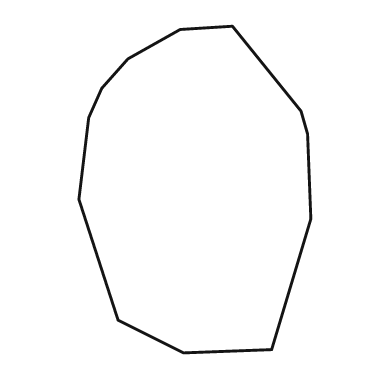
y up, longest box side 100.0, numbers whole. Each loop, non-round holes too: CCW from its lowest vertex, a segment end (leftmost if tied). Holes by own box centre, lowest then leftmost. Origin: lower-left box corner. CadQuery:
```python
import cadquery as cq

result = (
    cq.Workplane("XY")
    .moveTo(32.0, 0.0)
    .lineTo(59.0, 1.0)
    .lineTo(71.0, 41.0)
    .lineTo(70.0, 67.0)
    .lineTo(68.0, 74.0)
    .lineTo(47.0, 100.0)
    .lineTo(31.0, 99.0)
    .lineTo(15.0, 90.0)
    .lineTo(7.0, 81.0)
    .lineTo(3.0, 72.0)
    .lineTo(0.0, 47.0)
    .lineTo(12.0, 10.0)
    .close()
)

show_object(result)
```